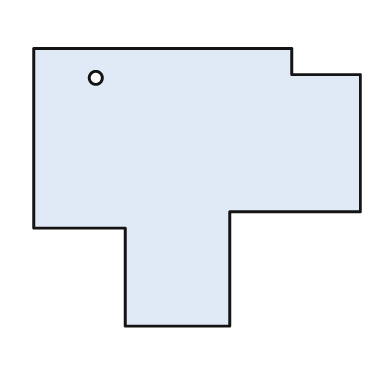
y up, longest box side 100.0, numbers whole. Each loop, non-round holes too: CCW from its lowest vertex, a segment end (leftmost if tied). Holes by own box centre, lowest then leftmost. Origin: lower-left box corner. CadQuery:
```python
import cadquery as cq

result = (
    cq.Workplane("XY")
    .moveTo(28.0, 0.0)
    .lineTo(60.0, 0.0)
    .lineTo(60.0, 35.0)
    .lineTo(100.0, 35.0)
    .lineTo(100.0, 77.0)
    .lineTo(79.0, 77.0)
    .lineTo(79.0, 85.0)
    .lineTo(0.0, 85.0)
    .lineTo(0.0, 30.0)
    .lineTo(28.0, 30.0)
    .close()
    .moveTo(19.0, 76.0)
    .circle(2.0)
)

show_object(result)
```